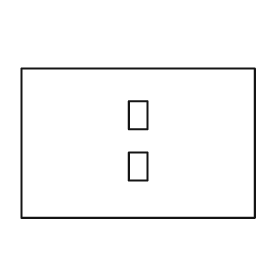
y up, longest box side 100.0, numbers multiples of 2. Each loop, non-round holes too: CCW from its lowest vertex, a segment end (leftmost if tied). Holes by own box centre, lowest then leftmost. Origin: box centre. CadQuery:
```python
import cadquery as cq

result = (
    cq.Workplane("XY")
    .moveTo(-50.0, -32.0)
    .lineTo(50.0, -32.0)
    .lineTo(50.0, 32.0)
    .lineTo(-50.0, 32.0)
    .close()
    .moveTo(-4.0, -16.0)
    .lineTo(4.0, -16.0)
    .lineTo(4.0, -4.0)
    .lineTo(-4.0, -4.0)
    .close()
    .moveTo(-4.0, 6.0)
    .lineTo(4.0, 6.0)
    .lineTo(4.0, 18.0)
    .lineTo(-4.0, 18.0)
    .close()
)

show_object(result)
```